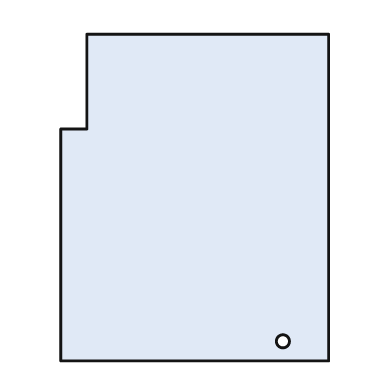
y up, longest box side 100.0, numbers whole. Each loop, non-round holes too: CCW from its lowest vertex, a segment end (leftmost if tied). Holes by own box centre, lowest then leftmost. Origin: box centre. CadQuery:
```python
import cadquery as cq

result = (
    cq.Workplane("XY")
    .moveTo(-41.0, -50.0)
    .lineTo(41.0, -50.0)
    .lineTo(41.0, 50.0)
    .lineTo(-33.0, 50.0)
    .lineTo(-33.0, 21.0)
    .lineTo(-41.0, 21.0)
    .close()
    .moveTo(27.0, -44.0)
    .circle(2.0)
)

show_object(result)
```